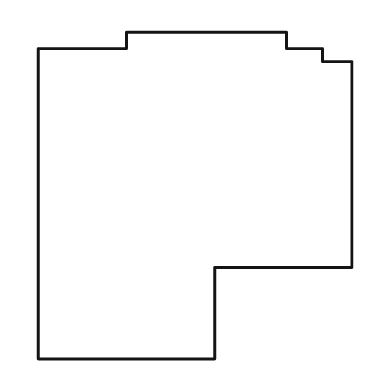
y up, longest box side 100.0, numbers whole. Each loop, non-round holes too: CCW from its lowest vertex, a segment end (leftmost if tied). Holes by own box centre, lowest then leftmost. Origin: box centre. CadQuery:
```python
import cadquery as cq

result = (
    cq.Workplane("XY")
    .moveTo(-48.0, -50.0)
    .lineTo(6.0, -50.0)
    .lineTo(6.0, -22.0)
    .lineTo(48.0, -22.0)
    .lineTo(48.0, 41.0)
    .lineTo(39.0, 41.0)
    .lineTo(39.0, 45.0)
    .lineTo(28.0, 45.0)
    .lineTo(28.0, 50.0)
    .lineTo(-21.0, 50.0)
    .lineTo(-21.0, 45.0)
    .lineTo(-48.0, 45.0)
    .close()
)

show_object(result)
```